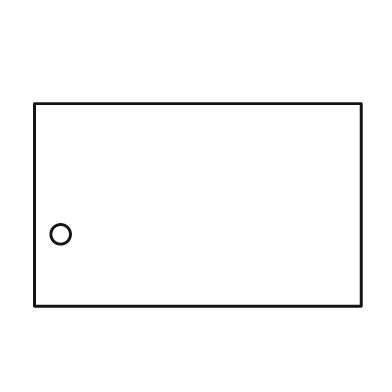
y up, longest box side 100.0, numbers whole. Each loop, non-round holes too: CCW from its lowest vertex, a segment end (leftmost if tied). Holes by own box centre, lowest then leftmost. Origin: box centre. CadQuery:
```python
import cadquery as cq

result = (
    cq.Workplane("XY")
    .moveTo(-50.0, -31.0)
    .lineTo(50.0, -31.0)
    .lineTo(50.0, 31.0)
    .lineTo(-50.0, 31.0)
    .close()
    .moveTo(-42.0, -9.0)
    .circle(3.0)
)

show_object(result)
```